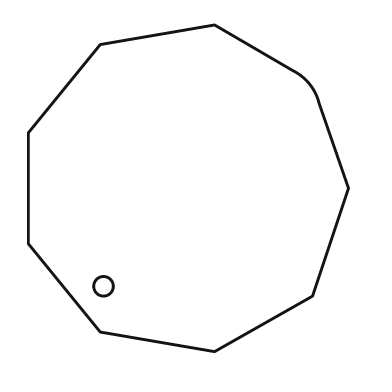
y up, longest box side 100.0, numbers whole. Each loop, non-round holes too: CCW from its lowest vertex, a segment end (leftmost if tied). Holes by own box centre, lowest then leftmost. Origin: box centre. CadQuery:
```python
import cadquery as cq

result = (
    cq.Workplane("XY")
    .moveTo(8.0, -50.0)
    .lineTo(38.0, -33.0)
    .lineTo(49.0, 0.0)
    .lineTo(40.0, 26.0)
    .threePointArc((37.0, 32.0), (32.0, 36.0))
    .lineTo(8.0, 50.0)
    .lineTo(-27.0, 44.0)
    .lineTo(-49.0, 17.0)
    .lineTo(-49.0, -17.0)
    .lineTo(-27.0, -44.0)
    .close()
    .moveTo(-26.0, -30.0)
    .circle(3.0)
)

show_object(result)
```